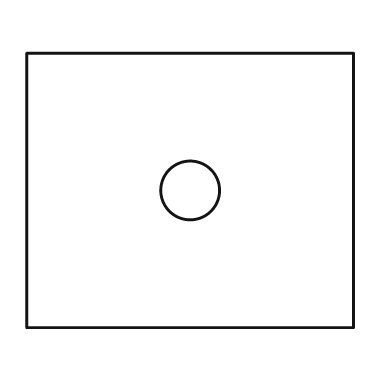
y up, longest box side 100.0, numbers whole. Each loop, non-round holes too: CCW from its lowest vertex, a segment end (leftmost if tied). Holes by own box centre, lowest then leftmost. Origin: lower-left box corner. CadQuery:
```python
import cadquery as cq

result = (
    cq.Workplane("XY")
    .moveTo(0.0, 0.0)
    .lineTo(100.0, 0.0)
    .lineTo(100.0, 84.0)
    .lineTo(0.0, 84.0)
    .close()
    .moveTo(50.0, 42.0)
    .circle(9.0)
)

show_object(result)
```